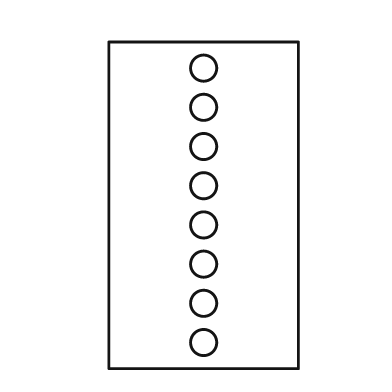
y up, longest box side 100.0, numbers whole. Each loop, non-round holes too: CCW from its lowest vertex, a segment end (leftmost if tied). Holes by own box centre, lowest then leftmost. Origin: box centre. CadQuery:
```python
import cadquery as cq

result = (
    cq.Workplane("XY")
    .moveTo(-29.0, -50.0)
    .lineTo(29.0, -50.0)
    .lineTo(29.0, 50.0)
    .lineTo(-29.0, 50.0)
    .close()
    .moveTo(0.0, -42.0)
    .circle(4.0)
    .moveTo(0.0, -30.0)
    .circle(4.0)
    .moveTo(0.0, -18.0)
    .circle(4.0)
    .moveTo(0.0, -6.0)
    .circle(4.0)
    .moveTo(0.0, 6.0)
    .circle(4.0)
    .moveTo(0.0, 18.0)
    .circle(4.0)
    .moveTo(0.0, 30.0)
    .circle(4.0)
    .moveTo(0.0, 42.0)
    .circle(4.0)
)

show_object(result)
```